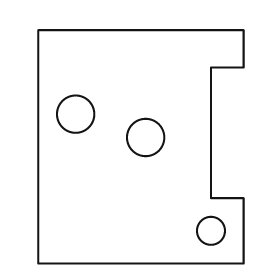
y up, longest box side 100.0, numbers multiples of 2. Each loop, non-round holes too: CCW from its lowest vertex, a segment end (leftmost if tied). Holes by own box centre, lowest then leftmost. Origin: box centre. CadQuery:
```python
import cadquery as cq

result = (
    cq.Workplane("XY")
    .moveTo(-44.0, -50.0)
    .lineTo(44.0, -50.0)
    .lineTo(44.0, -22.0)
    .lineTo(30.0, -22.0)
    .lineTo(30.0, 34.0)
    .lineTo(44.0, 34.0)
    .lineTo(44.0, 50.0)
    .lineTo(-44.0, 50.0)
    .close()
    .moveTo(30.0, -36.0)
    .circle(6.0)
    .moveTo(2.0, 4.0)
    .circle(8.0)
    .moveTo(-28.0, 14.0)
    .circle(8.0)
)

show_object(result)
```